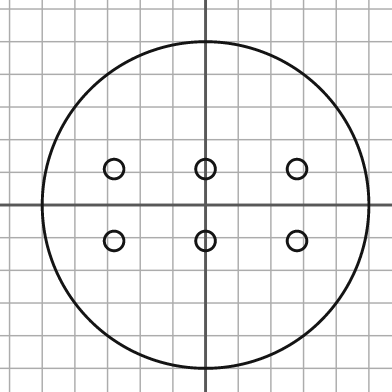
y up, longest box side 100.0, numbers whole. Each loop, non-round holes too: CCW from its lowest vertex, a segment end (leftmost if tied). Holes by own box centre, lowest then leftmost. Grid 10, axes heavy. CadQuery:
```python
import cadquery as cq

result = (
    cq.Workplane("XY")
    .moveTo(0.0, 0.0)
    .circle(50.0)
    .moveTo(-28.0, -11.0)
    .circle(3.0)
    .moveTo(0.0, -11.0)
    .circle(3.0)
    .moveTo(28.0, -11.0)
    .circle(3.0)
    .moveTo(-28.0, 11.0)
    .circle(3.0)
    .moveTo(0.0, 11.0)
    .circle(3.0)
    .moveTo(28.0, 11.0)
    .circle(3.0)
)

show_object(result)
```